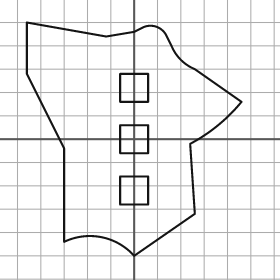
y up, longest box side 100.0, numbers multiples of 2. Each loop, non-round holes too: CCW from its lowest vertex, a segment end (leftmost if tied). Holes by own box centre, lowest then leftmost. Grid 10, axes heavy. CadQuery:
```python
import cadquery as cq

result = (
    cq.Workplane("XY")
    .moveTo(0.0, -50.0)
    .lineTo(26.0, -32.0)
    .lineTo(24.0, -2.0)
    .threePointArc((36.0, 6.0), (46.0, 16.0))
    .lineTo(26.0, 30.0)
    .threePointArc((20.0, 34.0), (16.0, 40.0))
    .lineTo(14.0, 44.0)
    .threePointArc((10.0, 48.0), (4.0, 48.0))
    .lineTo(0.0, 46.0)
    .lineTo(-12.0, 44.0)
    .lineTo(-46.0, 50.0)
    .lineTo(-46.0, 28.0)
    .lineTo(-30.0, -4.0)
    .lineTo(-30.0, -44.0)
    .threePointArc((-14.0, -42.0), (0.0, -50.0))
    .close()
    .moveTo(-6.0, -28.0)
    .lineTo(6.0, -28.0)
    .lineTo(6.0, -16.0)
    .lineTo(-6.0, -16.0)
    .close()
    .moveTo(-6.0, -6.0)
    .lineTo(6.0, -6.0)
    .lineTo(6.0, 6.0)
    .lineTo(-6.0, 6.0)
    .close()
    .moveTo(-6.0, 16.0)
    .lineTo(6.0, 16.0)
    .lineTo(6.0, 28.0)
    .lineTo(-6.0, 28.0)
    .close()
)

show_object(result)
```